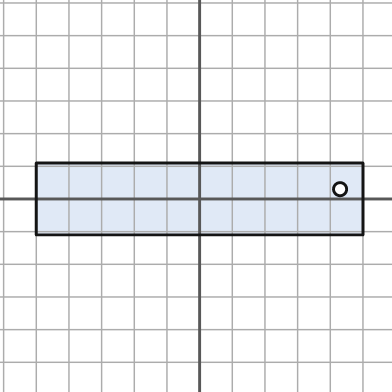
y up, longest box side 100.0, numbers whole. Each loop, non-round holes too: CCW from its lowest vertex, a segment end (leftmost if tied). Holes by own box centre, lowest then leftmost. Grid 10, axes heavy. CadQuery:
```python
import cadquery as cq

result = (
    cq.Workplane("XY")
    .moveTo(-50.0, -11.0)
    .lineTo(50.0, -11.0)
    .lineTo(50.0, 11.0)
    .lineTo(-50.0, 11.0)
    .close()
    .moveTo(43.0, 3.0)
    .circle(2.0)
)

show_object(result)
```